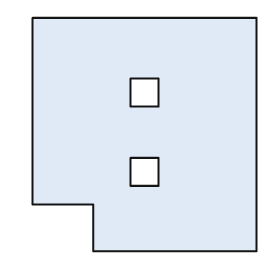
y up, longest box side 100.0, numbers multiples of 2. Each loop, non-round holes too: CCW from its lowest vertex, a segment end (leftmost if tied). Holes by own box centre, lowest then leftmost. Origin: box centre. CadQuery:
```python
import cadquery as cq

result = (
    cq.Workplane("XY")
    .moveTo(-22.0, -50.0)
    .lineTo(48.0, -50.0)
    .lineTo(48.0, 50.0)
    .lineTo(-48.0, 50.0)
    .lineTo(-48.0, -30.0)
    .lineTo(-22.0, -30.0)
    .close()
    .moveTo(-6.0, -22.0)
    .lineTo(6.0, -22.0)
    .lineTo(6.0, -10.0)
    .lineTo(-6.0, -10.0)
    .close()
    .moveTo(-6.0, 12.0)
    .lineTo(6.0, 12.0)
    .lineTo(6.0, 24.0)
    .lineTo(-6.0, 24.0)
    .close()
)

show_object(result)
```